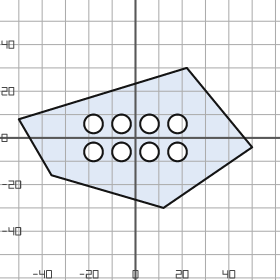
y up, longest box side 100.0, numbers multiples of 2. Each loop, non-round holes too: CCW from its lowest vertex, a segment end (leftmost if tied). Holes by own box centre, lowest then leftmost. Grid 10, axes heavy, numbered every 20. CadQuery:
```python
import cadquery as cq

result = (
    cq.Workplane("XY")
    .moveTo(12.0, -30.0)
    .lineTo(50.0, -4.0)
    .lineTo(22.0, 30.0)
    .lineTo(-50.0, 8.0)
    .lineTo(-36.0, -16.0)
    .close()
    .moveTo(-18.0, -6.0)
    .circle(4.0)
    .moveTo(-6.0, -6.0)
    .circle(4.0)
    .moveTo(6.0, -6.0)
    .circle(4.0)
    .moveTo(18.0, -6.0)
    .circle(4.0)
    .moveTo(-18.0, 6.0)
    .circle(4.0)
    .moveTo(-6.0, 6.0)
    .circle(4.0)
    .moveTo(6.0, 6.0)
    .circle(4.0)
    .moveTo(18.0, 6.0)
    .circle(4.0)
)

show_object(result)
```